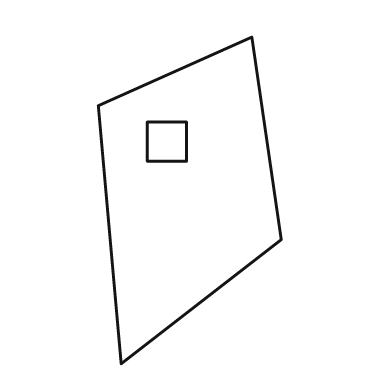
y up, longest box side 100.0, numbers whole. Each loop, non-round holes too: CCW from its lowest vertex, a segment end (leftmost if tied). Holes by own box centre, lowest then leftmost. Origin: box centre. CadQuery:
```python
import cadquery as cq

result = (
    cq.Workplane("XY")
    .moveTo(-21.0, -50.0)
    .lineTo(28.0, -12.0)
    .lineTo(19.0, 50.0)
    .lineTo(-28.0, 29.0)
    .close()
    .moveTo(-13.0, 12.0)
    .lineTo(-1.0, 12.0)
    .lineTo(-1.0, 24.0)
    .lineTo(-13.0, 24.0)
    .close()
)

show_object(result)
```